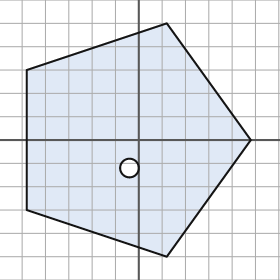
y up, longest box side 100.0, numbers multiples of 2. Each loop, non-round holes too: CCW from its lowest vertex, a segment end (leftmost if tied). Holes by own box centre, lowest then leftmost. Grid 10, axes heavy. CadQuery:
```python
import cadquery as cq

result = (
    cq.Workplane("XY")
    .moveTo(12.0, -50.0)
    .lineTo(48.0, 0.0)
    .lineTo(12.0, 50.0)
    .lineTo(-48.0, 30.0)
    .lineTo(-48.0, -30.0)
    .close()
    .moveTo(-4.0, -12.0)
    .circle(4.0)
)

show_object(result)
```